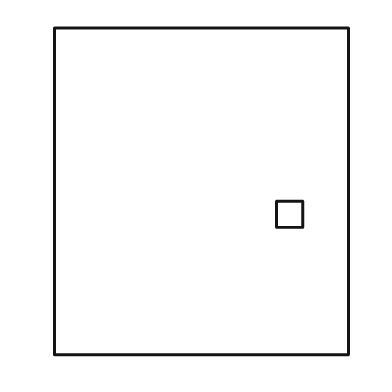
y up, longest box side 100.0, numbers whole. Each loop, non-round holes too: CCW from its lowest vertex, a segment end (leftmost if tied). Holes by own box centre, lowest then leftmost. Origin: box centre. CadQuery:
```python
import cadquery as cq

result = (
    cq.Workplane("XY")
    .moveTo(-45.0, -50.0)
    .lineTo(45.0, -50.0)
    .lineTo(45.0, 50.0)
    .lineTo(-45.0, 50.0)
    .close()
    .moveTo(23.0, -11.0)
    .lineTo(31.0, -11.0)
    .lineTo(31.0, -3.0)
    .lineTo(23.0, -3.0)
    .close()
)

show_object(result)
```